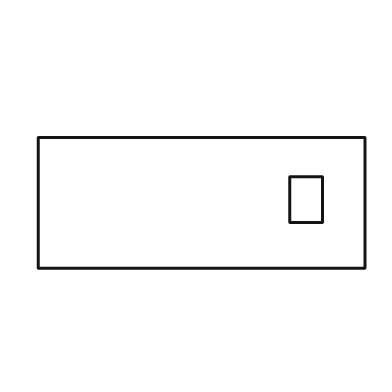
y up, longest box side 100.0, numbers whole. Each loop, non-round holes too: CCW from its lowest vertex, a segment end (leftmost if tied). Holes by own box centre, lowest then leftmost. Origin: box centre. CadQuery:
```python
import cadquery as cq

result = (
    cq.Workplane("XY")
    .moveTo(-50.0, -20.0)
    .lineTo(50.0, -20.0)
    .lineTo(50.0, 20.0)
    .lineTo(-50.0, 20.0)
    .close()
    .moveTo(27.0, -6.0)
    .lineTo(37.0, -6.0)
    .lineTo(37.0, 8.0)
    .lineTo(27.0, 8.0)
    .close()
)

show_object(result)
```